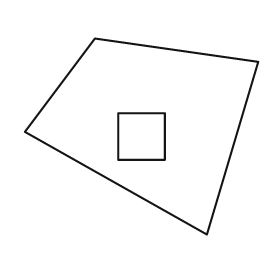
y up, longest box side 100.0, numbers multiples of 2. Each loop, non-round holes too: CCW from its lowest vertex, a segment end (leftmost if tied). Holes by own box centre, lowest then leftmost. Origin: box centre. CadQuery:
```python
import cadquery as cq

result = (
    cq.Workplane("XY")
    .moveTo(28.0, -42.0)
    .lineTo(50.0, 32.0)
    .lineTo(-20.0, 42.0)
    .lineTo(-50.0, 2.0)
    .close()
    .moveTo(-10.0, -10.0)
    .lineTo(10.0, -10.0)
    .lineTo(10.0, 10.0)
    .lineTo(-10.0, 10.0)
    .close()
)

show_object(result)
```